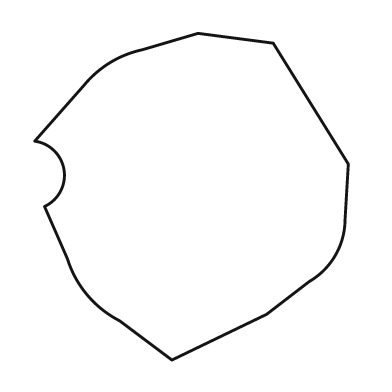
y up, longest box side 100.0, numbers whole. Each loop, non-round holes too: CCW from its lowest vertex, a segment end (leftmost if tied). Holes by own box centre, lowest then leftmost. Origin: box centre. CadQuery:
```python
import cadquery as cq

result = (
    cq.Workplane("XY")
    .moveTo(-6.0, -50.0)
    .lineTo(23.0, -36.0)
    .lineTo(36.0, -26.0)
    .threePointArc((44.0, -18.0), (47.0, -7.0))
    .lineTo(48.0, 10.0)
    .lineTo(25.0, 47.0)
    .lineTo(2.0, 50.0)
    .lineTo(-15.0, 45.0)
    .threePointArc((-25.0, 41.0), (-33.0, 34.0))
    .lineTo(-48.0, 17.0)
    .threePointArc((-39.0, 8.0), (-45.0, -3.0))
    .lineTo(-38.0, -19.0)
    .threePointArc((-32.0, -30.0), (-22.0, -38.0))
    .close()
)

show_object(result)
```